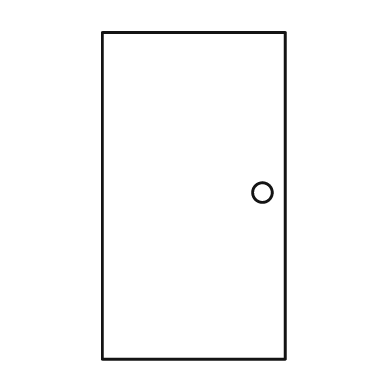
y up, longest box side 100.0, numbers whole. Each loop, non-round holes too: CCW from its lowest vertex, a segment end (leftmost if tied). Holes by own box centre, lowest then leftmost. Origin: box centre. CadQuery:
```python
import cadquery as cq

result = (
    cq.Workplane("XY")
    .moveTo(-28.0, -50.0)
    .lineTo(28.0, -50.0)
    .lineTo(28.0, 50.0)
    .lineTo(-28.0, 50.0)
    .close()
    .moveTo(21.0, 1.0)
    .circle(3.0)
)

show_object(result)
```